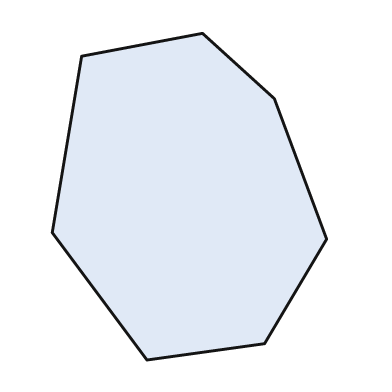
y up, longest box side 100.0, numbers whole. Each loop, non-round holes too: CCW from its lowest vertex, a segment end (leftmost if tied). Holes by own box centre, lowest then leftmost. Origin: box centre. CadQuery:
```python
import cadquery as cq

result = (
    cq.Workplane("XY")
    .moveTo(-13.0, -50.0)
    .lineTo(23.0, -45.0)
    .lineTo(42.0, -13.0)
    .lineTo(26.0, 30.0)
    .lineTo(4.0, 50.0)
    .lineTo(-33.0, 43.0)
    .lineTo(-42.0, -11.0)
    .close()
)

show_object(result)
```